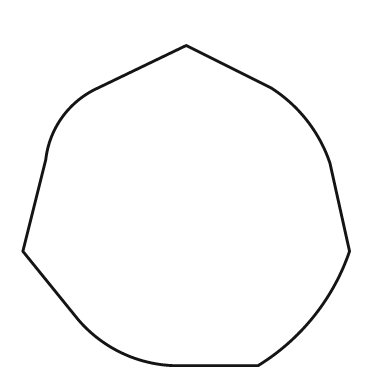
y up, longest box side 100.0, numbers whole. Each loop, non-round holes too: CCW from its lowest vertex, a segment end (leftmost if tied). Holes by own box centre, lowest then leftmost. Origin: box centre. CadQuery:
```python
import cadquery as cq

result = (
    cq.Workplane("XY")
    .moveTo(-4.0, -49.0)
    .lineTo(22.0, -49.0)
    .threePointArc((39.0, -34.0), (50.0, -14.0))
    .lineTo(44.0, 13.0)
    .threePointArc((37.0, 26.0), (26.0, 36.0))
    .lineTo(0.0, 49.0)
    .lineTo(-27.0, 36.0)
    .threePointArc((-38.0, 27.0), (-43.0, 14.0))
    .lineTo(-50.0, -14.0)
    .lineTo(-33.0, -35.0)
    .threePointArc((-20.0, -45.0), (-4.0, -49.0))
    .close()
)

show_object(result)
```